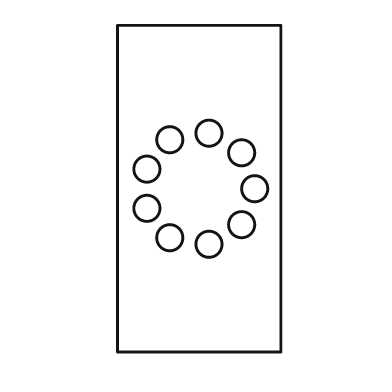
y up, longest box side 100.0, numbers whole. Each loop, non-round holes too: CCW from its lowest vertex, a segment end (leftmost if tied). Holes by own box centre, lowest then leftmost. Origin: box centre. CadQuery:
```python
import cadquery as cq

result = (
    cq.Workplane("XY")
    .moveTo(-25.0, -50.0)
    .lineTo(25.0, -50.0)
    .lineTo(25.0, 50.0)
    .lineTo(-25.0, 50.0)
    .close()
    .moveTo(3.0, -17.0)
    .circle(4.0)
    .moveTo(-9.0, -15.0)
    .circle(4.0)
    .moveTo(13.0, -11.0)
    .circle(4.0)
    .moveTo(-16.0, -6.0)
    .circle(4.0)
    .moveTo(17.0, 0.0)
    .circle(4.0)
    .moveTo(-16.0, 6.0)
    .circle(4.0)
    .moveTo(13.0, 11.0)
    .circle(4.0)
    .moveTo(-9.0, 15.0)
    .circle(4.0)
    .moveTo(3.0, 17.0)
    .circle(4.0)
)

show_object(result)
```